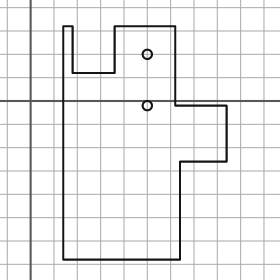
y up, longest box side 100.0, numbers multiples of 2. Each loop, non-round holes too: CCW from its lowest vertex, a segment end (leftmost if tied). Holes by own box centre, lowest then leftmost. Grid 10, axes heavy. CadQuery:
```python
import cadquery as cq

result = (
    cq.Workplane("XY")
    .moveTo(14.0, -68.0)
    .lineTo(64.0, -68.0)
    .lineTo(64.0, -26.0)
    .lineTo(84.0, -26.0)
    .lineTo(84.0, -2.0)
    .lineTo(62.0, -2.0)
    .lineTo(62.0, 32.0)
    .lineTo(36.0, 32.0)
    .lineTo(36.0, 12.0)
    .lineTo(18.0, 12.0)
    .lineTo(18.0, 32.0)
    .lineTo(14.0, 32.0)
    .close()
    .moveTo(50.0, -2.0)
    .circle(2.0)
    .moveTo(50.0, 20.0)
    .circle(2.0)
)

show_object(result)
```